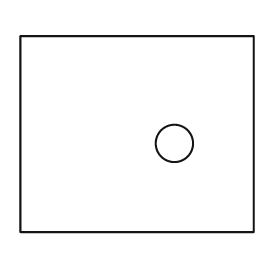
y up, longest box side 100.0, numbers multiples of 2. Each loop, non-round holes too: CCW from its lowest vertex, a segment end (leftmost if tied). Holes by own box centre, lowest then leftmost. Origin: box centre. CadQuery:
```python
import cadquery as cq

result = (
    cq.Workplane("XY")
    .moveTo(-50.0, -42.0)
    .lineTo(50.0, -42.0)
    .lineTo(50.0, 42.0)
    .lineTo(-50.0, 42.0)
    .close()
    .moveTo(16.0, -4.0)
    .circle(8.0)
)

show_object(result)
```